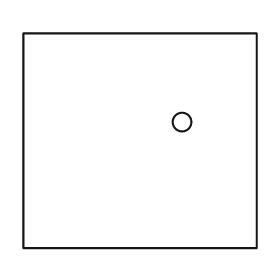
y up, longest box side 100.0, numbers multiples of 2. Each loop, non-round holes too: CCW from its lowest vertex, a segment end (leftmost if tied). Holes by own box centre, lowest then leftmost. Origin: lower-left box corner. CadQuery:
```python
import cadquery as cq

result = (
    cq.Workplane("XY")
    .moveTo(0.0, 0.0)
    .lineTo(100.0, 0.0)
    .lineTo(100.0, 92.0)
    .lineTo(0.0, 92.0)
    .close()
    .moveTo(68.0, 54.0)
    .circle(4.0)
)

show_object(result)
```